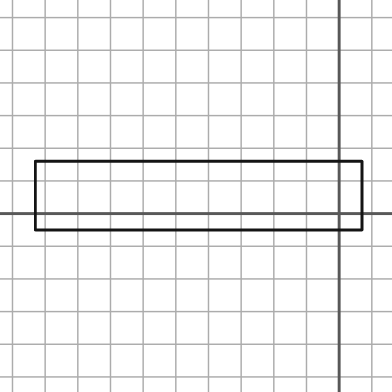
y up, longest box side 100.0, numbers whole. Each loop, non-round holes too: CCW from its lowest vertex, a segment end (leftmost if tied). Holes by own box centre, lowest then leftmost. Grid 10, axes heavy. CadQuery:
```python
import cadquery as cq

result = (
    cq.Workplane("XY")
    .moveTo(-93.0, -5.0)
    .lineTo(7.0, -5.0)
    .lineTo(7.0, 16.0)
    .lineTo(-93.0, 16.0)
    .close()
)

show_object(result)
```